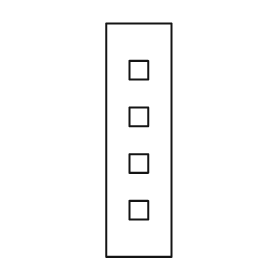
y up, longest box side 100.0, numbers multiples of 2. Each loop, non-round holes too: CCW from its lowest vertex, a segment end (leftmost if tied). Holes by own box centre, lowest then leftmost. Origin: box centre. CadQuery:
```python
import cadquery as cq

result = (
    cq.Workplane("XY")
    .moveTo(-14.0, -50.0)
    .lineTo(14.0, -50.0)
    .lineTo(14.0, 50.0)
    .lineTo(-14.0, 50.0)
    .close()
    .moveTo(-4.0, -34.0)
    .lineTo(4.0, -34.0)
    .lineTo(4.0, -26.0)
    .lineTo(-4.0, -26.0)
    .close()
    .moveTo(-4.0, -14.0)
    .lineTo(4.0, -14.0)
    .lineTo(4.0, -6.0)
    .lineTo(-4.0, -6.0)
    .close()
    .moveTo(-4.0, 6.0)
    .lineTo(4.0, 6.0)
    .lineTo(4.0, 14.0)
    .lineTo(-4.0, 14.0)
    .close()
    .moveTo(-4.0, 26.0)
    .lineTo(4.0, 26.0)
    .lineTo(4.0, 34.0)
    .lineTo(-4.0, 34.0)
    .close()
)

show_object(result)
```